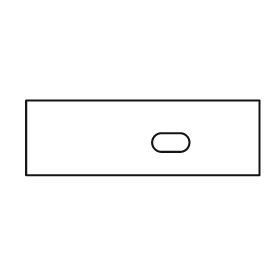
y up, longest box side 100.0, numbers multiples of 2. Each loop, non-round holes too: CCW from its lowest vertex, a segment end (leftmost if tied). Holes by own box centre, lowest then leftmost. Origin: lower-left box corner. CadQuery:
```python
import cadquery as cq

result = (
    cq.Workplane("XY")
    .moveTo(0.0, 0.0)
    .lineTo(100.0, 0.0)
    .lineTo(100.0, 32.0)
    .lineTo(0.0, 32.0)
    .close()
    .moveTo(58.0, 10.0)
    .lineTo(66.0, 10.0)
    .threePointArc((70.0, 14.0), (66.0, 18.0))
    .lineTo(58.0, 18.0)
    .threePointArc((54.0, 14.0), (58.0, 10.0))
    .close()
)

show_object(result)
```